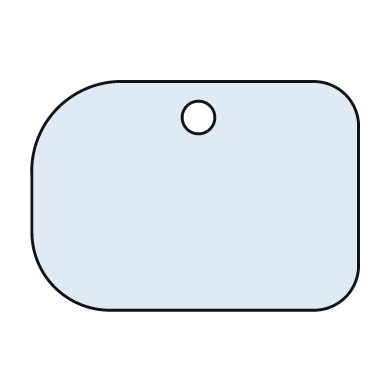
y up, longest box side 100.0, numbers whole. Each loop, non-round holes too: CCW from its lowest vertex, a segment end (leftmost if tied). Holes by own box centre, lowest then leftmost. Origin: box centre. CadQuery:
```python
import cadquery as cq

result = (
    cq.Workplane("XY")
    .moveTo(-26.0, -35.0)
    .lineTo(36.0, -35.0)
    .threePointArc((46.0, -31.0), (50.0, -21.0))
    .lineTo(50.0, 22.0)
    .threePointArc((46.0, 31.0), (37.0, 35.0))
    .lineTo(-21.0, 35.0)
    .threePointArc((-42.0, 27.0), (-50.0, 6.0))
    .lineTo(-50.0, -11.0)
    .threePointArc((-43.0, -28.0), (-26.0, -35.0))
    .close()
    .moveTo(1.0, 24.0)
    .circle(5.0)
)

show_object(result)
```